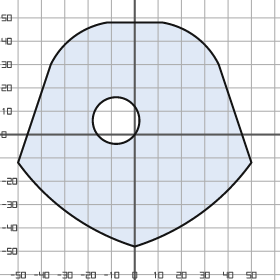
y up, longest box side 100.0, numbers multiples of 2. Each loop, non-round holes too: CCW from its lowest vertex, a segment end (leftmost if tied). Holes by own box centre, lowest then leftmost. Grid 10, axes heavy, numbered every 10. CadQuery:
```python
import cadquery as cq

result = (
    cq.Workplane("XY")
    .moveTo(0.0, -48.0)
    .threePointArc((28.0, -34.0), (50.0, -12.0))
    .lineTo(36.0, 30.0)
    .threePointArc((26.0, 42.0), (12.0, 48.0))
    .lineTo(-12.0, 48.0)
    .threePointArc((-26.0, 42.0), (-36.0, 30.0))
    .lineTo(-50.0, -12.0)
    .threePointArc((-28.0, -34.0), (0.0, -48.0))
    .close()
    .moveTo(-8.0, 6.0)
    .circle(10.0)
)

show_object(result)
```